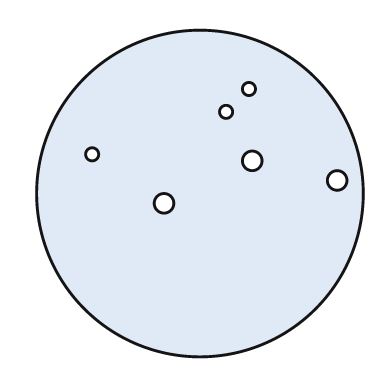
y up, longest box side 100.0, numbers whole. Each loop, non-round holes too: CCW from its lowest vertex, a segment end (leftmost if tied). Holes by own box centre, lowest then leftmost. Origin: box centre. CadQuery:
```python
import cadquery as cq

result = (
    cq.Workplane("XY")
    .moveTo(0.0, 0.0)
    .circle(50.0)
    .moveTo(-11.0, -3.0)
    .circle(3.0)
    .moveTo(42.0, 4.0)
    .circle(3.0)
    .moveTo(16.0, 10.0)
    .circle(3.0)
    .moveTo(-33.0, 12.0)
    .circle(2.0)
    .moveTo(8.0, 25.0)
    .circle(2.0)
    .moveTo(15.0, 32.0)
    .circle(2.0)
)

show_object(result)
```